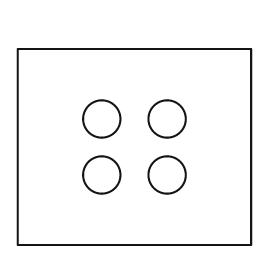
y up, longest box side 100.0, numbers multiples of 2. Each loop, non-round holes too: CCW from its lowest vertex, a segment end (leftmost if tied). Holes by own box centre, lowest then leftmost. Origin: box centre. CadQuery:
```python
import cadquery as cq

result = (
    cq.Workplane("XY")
    .moveTo(-50.0, -42.0)
    .lineTo(50.0, -42.0)
    .lineTo(50.0, 42.0)
    .lineTo(-50.0, 42.0)
    .close()
    .moveTo(-14.0, -12.0)
    .circle(8.0)
    .moveTo(14.0, -12.0)
    .circle(8.0)
    .moveTo(-14.0, 12.0)
    .circle(8.0)
    .moveTo(14.0, 12.0)
    .circle(8.0)
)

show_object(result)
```